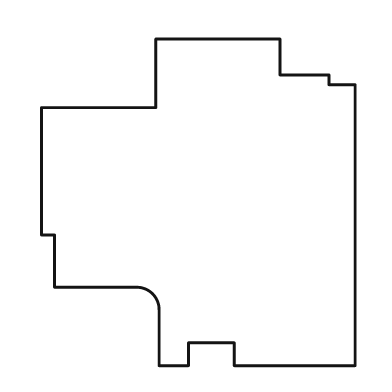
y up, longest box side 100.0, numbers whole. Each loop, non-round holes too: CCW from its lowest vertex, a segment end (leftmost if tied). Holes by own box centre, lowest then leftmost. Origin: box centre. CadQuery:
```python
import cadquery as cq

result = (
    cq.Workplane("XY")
    .moveTo(-12.0, -50.0)
    .lineTo(-3.0, -50.0)
    .lineTo(-3.0, -43.0)
    .lineTo(11.0, -43.0)
    .lineTo(11.0, -50.0)
    .lineTo(48.0, -50.0)
    .lineTo(48.0, 36.0)
    .lineTo(40.0, 36.0)
    .lineTo(40.0, 39.0)
    .lineTo(25.0, 39.0)
    .lineTo(25.0, 50.0)
    .lineTo(-13.0, 50.0)
    .lineTo(-13.0, 29.0)
    .lineTo(-48.0, 29.0)
    .lineTo(-48.0, -10.0)
    .lineTo(-44.0, -10.0)
    .lineTo(-44.0, -26.0)
    .lineTo(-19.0, -26.0)
    .threePointArc((-14.0, -28.0), (-12.0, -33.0))
    .close()
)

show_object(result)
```